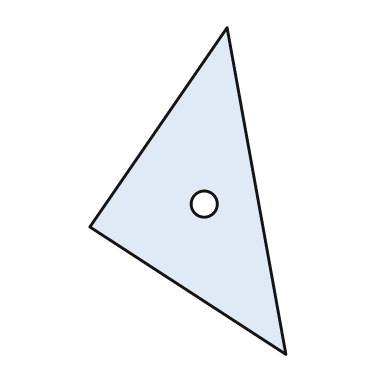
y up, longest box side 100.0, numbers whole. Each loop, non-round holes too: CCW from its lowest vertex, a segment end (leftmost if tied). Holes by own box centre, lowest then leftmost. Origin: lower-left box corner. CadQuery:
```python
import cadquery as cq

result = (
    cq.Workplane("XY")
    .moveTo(60.0, 0.0)
    .lineTo(42.0, 100.0)
    .lineTo(0.0, 39.0)
    .close()
    .moveTo(35.0, 46.0)
    .circle(4.0)
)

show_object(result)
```